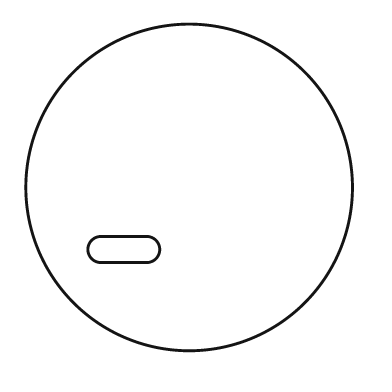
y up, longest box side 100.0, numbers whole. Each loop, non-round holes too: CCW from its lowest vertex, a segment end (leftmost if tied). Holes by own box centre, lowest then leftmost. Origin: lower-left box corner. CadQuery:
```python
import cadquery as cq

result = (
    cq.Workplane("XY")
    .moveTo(50.0, 50.0)
    .circle(50.0)
    .moveTo(23.0, 27.0)
    .lineTo(37.0, 27.0)
    .threePointArc((41.0, 31.0), (37.0, 35.0))
    .lineTo(23.0, 35.0)
    .threePointArc((19.0, 31.0), (23.0, 27.0))
    .close()
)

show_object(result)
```